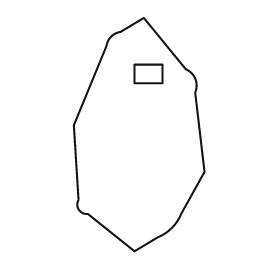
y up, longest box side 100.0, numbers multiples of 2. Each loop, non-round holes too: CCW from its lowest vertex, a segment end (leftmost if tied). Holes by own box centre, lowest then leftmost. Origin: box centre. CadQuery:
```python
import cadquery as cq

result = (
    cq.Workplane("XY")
    .moveTo(-2.0, -50.0)
    .lineTo(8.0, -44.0)
    .threePointArc((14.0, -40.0), (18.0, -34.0))
    .lineTo(28.0, -16.0)
    .lineTo(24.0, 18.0)
    .threePointArc((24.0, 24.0), (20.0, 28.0))
    .lineTo(2.0, 50.0)
    .lineTo(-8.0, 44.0)
    .threePointArc((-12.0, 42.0), (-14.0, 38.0))
    .lineTo(-28.0, 4.0)
    .lineTo(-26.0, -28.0)
    .threePointArc((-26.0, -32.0), (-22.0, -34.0))
    .close()
    .moveTo(-2.0, 22.0)
    .lineTo(10.0, 22.0)
    .lineTo(10.0, 30.0)
    .lineTo(-2.0, 30.0)
    .close()
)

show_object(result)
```